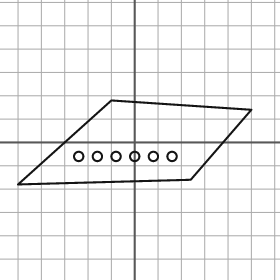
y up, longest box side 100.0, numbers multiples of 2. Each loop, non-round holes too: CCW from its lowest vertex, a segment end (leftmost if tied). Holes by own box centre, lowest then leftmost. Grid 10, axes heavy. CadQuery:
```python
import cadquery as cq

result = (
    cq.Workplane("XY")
    .moveTo(-50.0, -18.0)
    .lineTo(24.0, -16.0)
    .lineTo(50.0, 14.0)
    .lineTo(-10.0, 18.0)
    .close()
    .moveTo(-24.0, -6.0)
    .circle(2.0)
    .moveTo(-16.0, -6.0)
    .circle(2.0)
    .moveTo(-8.0, -6.0)
    .circle(2.0)
    .moveTo(0.0, -6.0)
    .circle(2.0)
    .moveTo(8.0, -6.0)
    .circle(2.0)
    .moveTo(16.0, -6.0)
    .circle(2.0)
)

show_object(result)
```